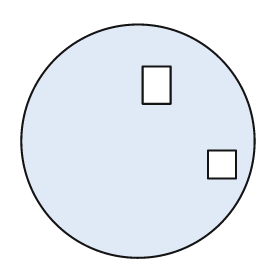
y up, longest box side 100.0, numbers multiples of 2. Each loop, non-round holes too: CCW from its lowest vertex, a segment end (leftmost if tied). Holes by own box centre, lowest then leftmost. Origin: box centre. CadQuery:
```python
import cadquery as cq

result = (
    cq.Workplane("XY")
    .moveTo(0.0, 0.0)
    .circle(50.0)
    .moveTo(30.0, -16.0)
    .lineTo(42.0, -16.0)
    .lineTo(42.0, -4.0)
    .lineTo(30.0, -4.0)
    .close()
    .moveTo(2.0, 16.0)
    .lineTo(14.0, 16.0)
    .lineTo(14.0, 32.0)
    .lineTo(2.0, 32.0)
    .close()
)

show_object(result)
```